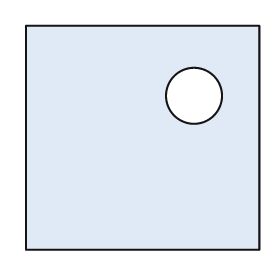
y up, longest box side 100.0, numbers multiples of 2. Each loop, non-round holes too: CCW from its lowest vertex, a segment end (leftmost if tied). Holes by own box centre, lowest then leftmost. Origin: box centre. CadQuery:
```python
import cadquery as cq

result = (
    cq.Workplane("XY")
    .moveTo(-50.0, -48.0)
    .lineTo(50.0, -48.0)
    .lineTo(50.0, 48.0)
    .lineTo(-50.0, 48.0)
    .close()
    .moveTo(22.0, 18.0)
    .circle(12.0)
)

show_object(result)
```